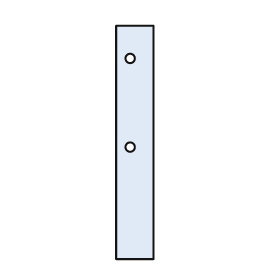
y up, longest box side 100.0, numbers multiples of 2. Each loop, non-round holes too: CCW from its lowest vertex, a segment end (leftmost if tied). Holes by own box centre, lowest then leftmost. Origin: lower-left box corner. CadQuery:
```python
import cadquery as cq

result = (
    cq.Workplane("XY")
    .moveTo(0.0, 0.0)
    .lineTo(16.0, 0.0)
    .lineTo(16.0, 100.0)
    .lineTo(0.0, 100.0)
    .close()
    .moveTo(6.0, 48.0)
    .circle(2.0)
    .moveTo(6.0, 86.0)
    .circle(2.0)
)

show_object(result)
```